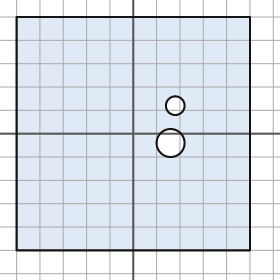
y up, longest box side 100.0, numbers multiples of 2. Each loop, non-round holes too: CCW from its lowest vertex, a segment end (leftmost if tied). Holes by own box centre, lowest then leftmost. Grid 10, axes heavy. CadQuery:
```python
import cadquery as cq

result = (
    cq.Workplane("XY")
    .moveTo(-50.0, -50.0)
    .lineTo(50.0, -50.0)
    .lineTo(50.0, 50.0)
    .lineTo(-50.0, 50.0)
    .close()
    .moveTo(16.0, -4.0)
    .circle(6.0)
    .moveTo(18.0, 12.0)
    .circle(4.0)
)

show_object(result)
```